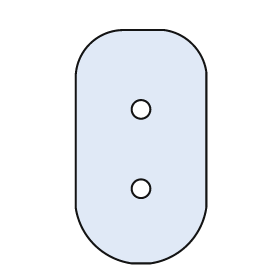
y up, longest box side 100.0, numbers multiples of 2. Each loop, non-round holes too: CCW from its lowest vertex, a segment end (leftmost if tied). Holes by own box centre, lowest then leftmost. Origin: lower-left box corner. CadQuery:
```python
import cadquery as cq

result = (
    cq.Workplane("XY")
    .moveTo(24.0, 0.0)
    .lineTo(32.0, 0.0)
    .threePointArc((48.0, 8.0), (56.0, 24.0))
    .lineTo(56.0, 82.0)
    .threePointArc((50.0, 94.0), (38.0, 100.0))
    .lineTo(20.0, 100.0)
    .threePointArc((6.0, 94.0), (0.0, 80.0))
    .lineTo(0.0, 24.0)
    .threePointArc((8.0, 8.0), (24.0, 0.0))
    .close()
    .moveTo(28.0, 32.0)
    .circle(4.0)
    .moveTo(28.0, 66.0)
    .circle(4.0)
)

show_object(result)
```